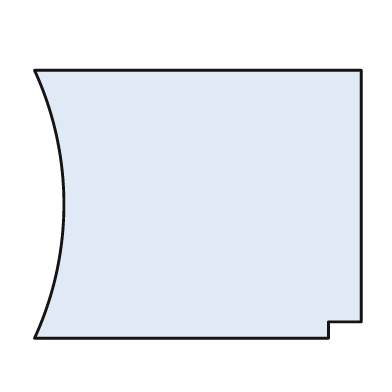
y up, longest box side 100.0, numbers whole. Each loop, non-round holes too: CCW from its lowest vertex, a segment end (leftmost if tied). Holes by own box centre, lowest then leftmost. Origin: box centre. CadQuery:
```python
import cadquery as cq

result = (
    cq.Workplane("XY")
    .moveTo(-50.0, -41.0)
    .lineTo(40.0, -41.0)
    .lineTo(40.0, -36.0)
    .lineTo(50.0, -36.0)
    .lineTo(50.0, 41.0)
    .lineTo(-50.0, 41.0)
    .threePointArc((-41.0, 0.0), (-50.0, -41.0))
    .close()
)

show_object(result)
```